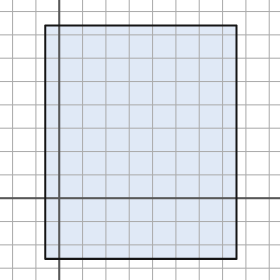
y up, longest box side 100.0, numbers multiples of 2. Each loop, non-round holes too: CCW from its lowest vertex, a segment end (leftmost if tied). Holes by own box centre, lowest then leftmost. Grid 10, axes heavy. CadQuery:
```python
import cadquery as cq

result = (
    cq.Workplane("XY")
    .moveTo(-6.0, -26.0)
    .lineTo(76.0, -26.0)
    .lineTo(76.0, 74.0)
    .lineTo(-6.0, 74.0)
    .close()
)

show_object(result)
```